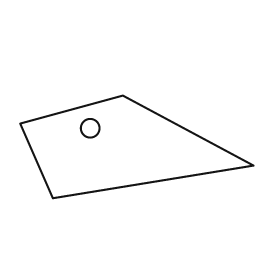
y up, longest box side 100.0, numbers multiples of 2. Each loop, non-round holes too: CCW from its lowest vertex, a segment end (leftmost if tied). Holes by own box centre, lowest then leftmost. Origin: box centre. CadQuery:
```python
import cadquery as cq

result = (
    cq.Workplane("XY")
    .moveTo(-36.0, -22.0)
    .lineTo(50.0, -8.0)
    .lineTo(-6.0, 22.0)
    .lineTo(-50.0, 10.0)
    .close()
    .moveTo(-20.0, 8.0)
    .circle(4.0)
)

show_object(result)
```